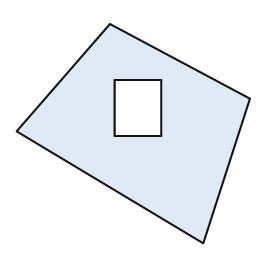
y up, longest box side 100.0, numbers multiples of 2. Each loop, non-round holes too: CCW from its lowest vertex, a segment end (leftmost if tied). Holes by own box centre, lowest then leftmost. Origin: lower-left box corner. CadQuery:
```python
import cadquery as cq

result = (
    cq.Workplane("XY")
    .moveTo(80.0, 0.0)
    .lineTo(100.0, 62.0)
    .lineTo(40.0, 94.0)
    .lineTo(0.0, 48.0)
    .close()
    .moveTo(42.0, 46.0)
    .lineTo(62.0, 46.0)
    .lineTo(62.0, 70.0)
    .lineTo(42.0, 70.0)
    .close()
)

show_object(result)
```